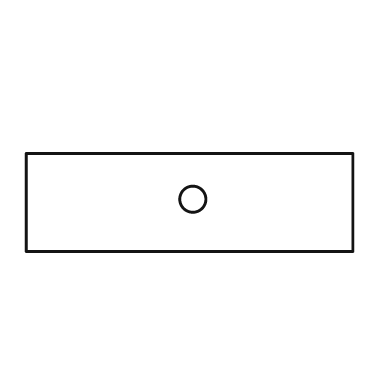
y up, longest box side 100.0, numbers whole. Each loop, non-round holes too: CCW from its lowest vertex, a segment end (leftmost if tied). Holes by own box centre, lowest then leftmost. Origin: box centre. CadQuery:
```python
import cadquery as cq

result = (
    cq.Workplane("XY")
    .moveTo(-50.0, -15.0)
    .lineTo(50.0, -15.0)
    .lineTo(50.0, 15.0)
    .lineTo(-50.0, 15.0)
    .close()
    .moveTo(1.0, 1.0)
    .circle(4.0)
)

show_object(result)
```